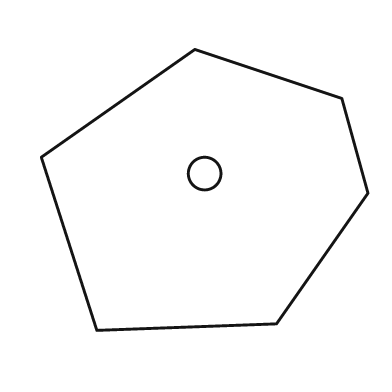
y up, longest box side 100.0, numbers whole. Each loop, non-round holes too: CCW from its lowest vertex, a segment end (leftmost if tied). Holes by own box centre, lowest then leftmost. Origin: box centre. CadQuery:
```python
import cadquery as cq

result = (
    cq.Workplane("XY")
    .moveTo(-33.0, -43.0)
    .lineTo(22.0, -41.0)
    .lineTo(50.0, -1.0)
    .lineTo(42.0, 28.0)
    .lineTo(-3.0, 43.0)
    .lineTo(-50.0, 10.0)
    .close()
    .moveTo(0.0, 5.0)
    .circle(5.0)
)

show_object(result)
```